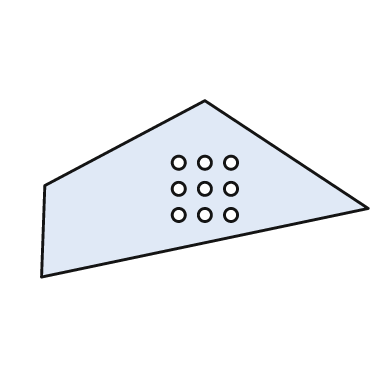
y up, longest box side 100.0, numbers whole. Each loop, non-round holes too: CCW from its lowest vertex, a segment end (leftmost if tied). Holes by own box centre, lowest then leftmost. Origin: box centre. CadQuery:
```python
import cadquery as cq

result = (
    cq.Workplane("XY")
    .moveTo(-50.0, -27.0)
    .lineTo(50.0, -6.0)
    .lineTo(0.0, 27.0)
    .lineTo(-49.0, 1.0)
    .close()
    .moveTo(-8.0, -8.0)
    .circle(2.0)
    .moveTo(0.0, -8.0)
    .circle(2.0)
    .moveTo(8.0, -8.0)
    .circle(2.0)
    .moveTo(-8.0, 0.0)
    .circle(2.0)
    .moveTo(0.0, 0.0)
    .circle(2.0)
    .moveTo(8.0, 0.0)
    .circle(2.0)
    .moveTo(-8.0, 8.0)
    .circle(2.0)
    .moveTo(0.0, 8.0)
    .circle(2.0)
    .moveTo(8.0, 8.0)
    .circle(2.0)
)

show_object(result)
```